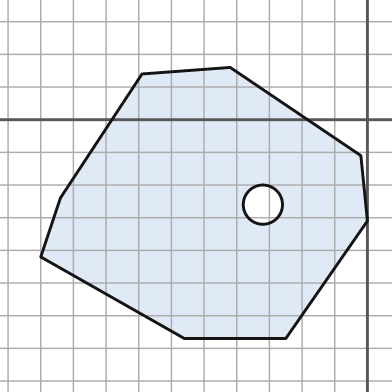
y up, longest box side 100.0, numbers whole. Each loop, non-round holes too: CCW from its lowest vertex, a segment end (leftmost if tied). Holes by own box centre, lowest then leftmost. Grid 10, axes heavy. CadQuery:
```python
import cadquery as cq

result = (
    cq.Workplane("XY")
    .moveTo(-56.0, -67.0)
    .lineTo(-25.0, -67.0)
    .lineTo(0.0, -31.0)
    .lineTo(-2.0, -11.0)
    .lineTo(-42.0, 16.0)
    .lineTo(-69.0, 14.0)
    .lineTo(-94.0, -24.0)
    .lineTo(-100.0, -42.0)
    .close()
    .moveTo(-32.0, -26.0)
    .circle(6.0)
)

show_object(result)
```